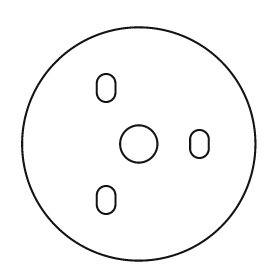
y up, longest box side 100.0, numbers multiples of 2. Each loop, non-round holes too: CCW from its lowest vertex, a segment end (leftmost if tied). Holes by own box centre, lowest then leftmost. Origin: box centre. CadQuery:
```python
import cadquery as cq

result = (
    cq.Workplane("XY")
    .moveTo(0.0, 0.0)
    .circle(50.0)
    .moveTo(-18.0, -26.0)
    .threePointArc((-14.0, -30.0), (-10.0, -26.0))
    .lineTo(-10.0, -22.0)
    .threePointArc((-14.0, -18.0), (-18.0, -22.0))
    .close()
    .moveTo(0.0, 0.0)
    .circle(8.0)
    .moveTo(22.0, -2.0)
    .threePointArc((26.0, -6.0), (30.0, -2.0))
    .lineTo(30.0, 2.0)
    .threePointArc((26.0, 6.0), (22.0, 2.0))
    .close()
    .moveTo(-18.0, 22.0)
    .threePointArc((-14.0, 18.0), (-10.0, 22.0))
    .lineTo(-10.0, 26.0)
    .threePointArc((-14.0, 30.0), (-18.0, 26.0))
    .close()
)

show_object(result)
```